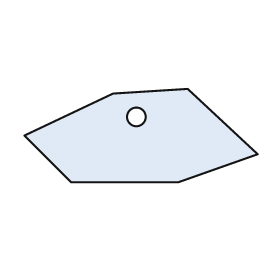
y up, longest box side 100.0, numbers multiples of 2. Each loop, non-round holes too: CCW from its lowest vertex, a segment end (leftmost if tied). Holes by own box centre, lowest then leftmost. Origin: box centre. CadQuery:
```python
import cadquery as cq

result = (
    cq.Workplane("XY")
    .moveTo(-30.0, -20.0)
    .lineTo(16.0, -20.0)
    .lineTo(50.0, -8.0)
    .lineTo(20.0, 20.0)
    .lineTo(-12.0, 18.0)
    .lineTo(-50.0, 0.0)
    .close()
    .moveTo(-2.0, 8.0)
    .circle(4.0)
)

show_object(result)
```